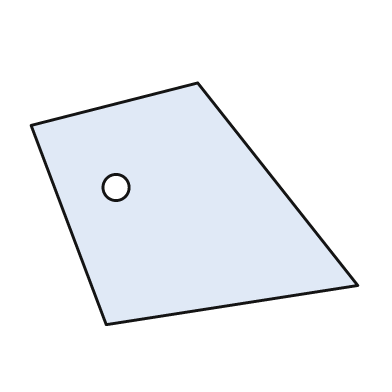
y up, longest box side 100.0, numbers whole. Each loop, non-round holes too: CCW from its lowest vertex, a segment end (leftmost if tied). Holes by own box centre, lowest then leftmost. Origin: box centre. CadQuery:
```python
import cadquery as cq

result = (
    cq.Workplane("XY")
    .moveTo(-27.0, -37.0)
    .lineTo(50.0, -25.0)
    .lineTo(1.0, 37.0)
    .lineTo(-50.0, 24.0)
    .close()
    .moveTo(-24.0, 5.0)
    .circle(4.0)
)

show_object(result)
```